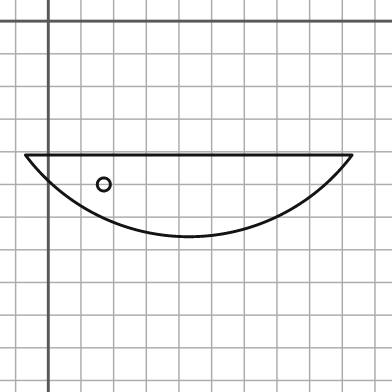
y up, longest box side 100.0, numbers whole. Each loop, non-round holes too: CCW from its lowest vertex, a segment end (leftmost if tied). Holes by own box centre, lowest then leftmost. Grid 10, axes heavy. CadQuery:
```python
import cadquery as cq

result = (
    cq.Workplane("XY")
    .moveTo(-7.0, -41.0)
    .threePointArc((43.0, -66.0), (93.0, -41.0))
    .close()
    .moveTo(17.0, -50.0)
    .circle(2.0)
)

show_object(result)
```